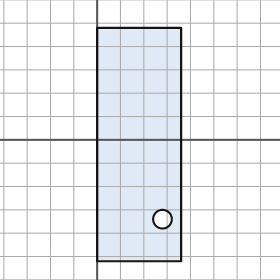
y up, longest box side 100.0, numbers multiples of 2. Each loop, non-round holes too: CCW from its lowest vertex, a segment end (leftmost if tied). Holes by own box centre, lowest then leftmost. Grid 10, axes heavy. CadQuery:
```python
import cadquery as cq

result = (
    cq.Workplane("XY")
    .moveTo(0.0, -52.0)
    .lineTo(36.0, -52.0)
    .lineTo(36.0, 48.0)
    .lineTo(0.0, 48.0)
    .close()
    .moveTo(28.0, -34.0)
    .circle(4.0)
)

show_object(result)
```